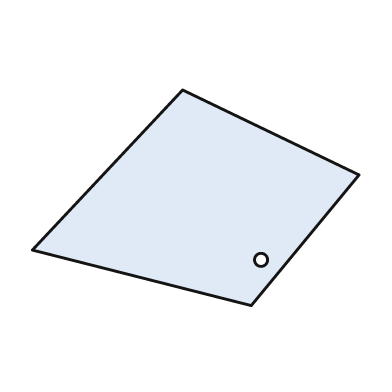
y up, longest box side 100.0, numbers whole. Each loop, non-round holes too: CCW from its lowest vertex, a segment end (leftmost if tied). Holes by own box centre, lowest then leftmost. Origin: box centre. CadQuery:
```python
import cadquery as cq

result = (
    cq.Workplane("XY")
    .moveTo(17.0, -33.0)
    .lineTo(50.0, 7.0)
    .lineTo(-4.0, 33.0)
    .lineTo(-50.0, -16.0)
    .close()
    .moveTo(20.0, -19.0)
    .circle(2.0)
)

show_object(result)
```